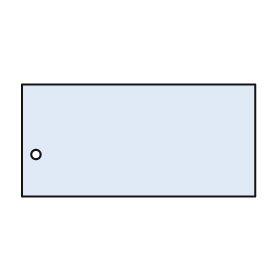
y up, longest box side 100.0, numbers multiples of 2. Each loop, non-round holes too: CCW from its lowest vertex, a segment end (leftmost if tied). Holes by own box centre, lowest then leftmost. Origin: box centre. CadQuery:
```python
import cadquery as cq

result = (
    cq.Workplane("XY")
    .moveTo(-50.0, -24.0)
    .lineTo(50.0, -24.0)
    .lineTo(50.0, 24.0)
    .lineTo(-50.0, 24.0)
    .close()
    .moveTo(-44.0, -6.0)
    .circle(2.0)
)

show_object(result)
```